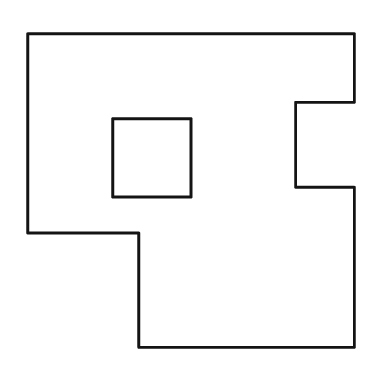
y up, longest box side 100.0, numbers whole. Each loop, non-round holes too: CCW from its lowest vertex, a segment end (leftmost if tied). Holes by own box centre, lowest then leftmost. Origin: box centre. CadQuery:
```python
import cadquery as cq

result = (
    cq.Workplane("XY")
    .moveTo(-16.0, -48.0)
    .lineTo(50.0, -48.0)
    .lineTo(50.0, 1.0)
    .lineTo(32.0, 1.0)
    .lineTo(32.0, 27.0)
    .lineTo(50.0, 27.0)
    .lineTo(50.0, 48.0)
    .lineTo(-50.0, 48.0)
    .lineTo(-50.0, -13.0)
    .lineTo(-16.0, -13.0)
    .close()
    .moveTo(-24.0, -2.0)
    .lineTo(0.0, -2.0)
    .lineTo(0.0, 22.0)
    .lineTo(-24.0, 22.0)
    .close()
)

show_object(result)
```